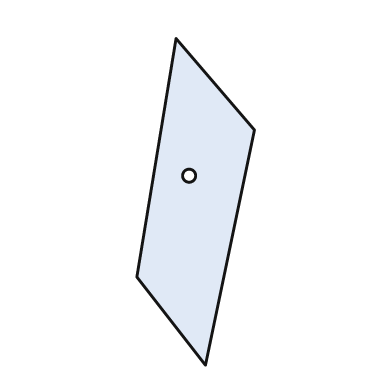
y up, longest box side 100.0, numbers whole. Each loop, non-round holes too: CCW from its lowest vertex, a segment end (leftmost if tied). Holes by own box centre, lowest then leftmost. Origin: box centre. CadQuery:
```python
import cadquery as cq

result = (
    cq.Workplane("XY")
    .moveTo(3.0, -50.0)
    .lineTo(18.0, 22.0)
    .lineTo(-6.0, 50.0)
    .lineTo(-18.0, -23.0)
    .close()
    .moveTo(-2.0, 8.0)
    .circle(2.0)
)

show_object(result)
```